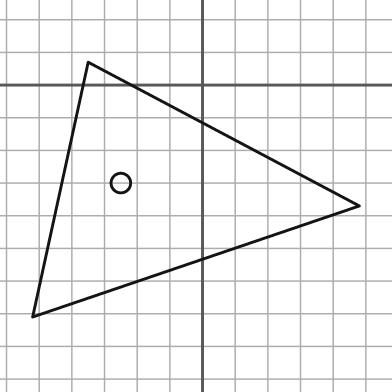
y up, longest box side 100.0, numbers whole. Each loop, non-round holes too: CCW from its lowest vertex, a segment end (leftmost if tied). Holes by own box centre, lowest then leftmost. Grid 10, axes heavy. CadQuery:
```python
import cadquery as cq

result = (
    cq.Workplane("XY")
    .moveTo(-52.0, -71.0)
    .lineTo(48.0, -37.0)
    .lineTo(-35.0, 7.0)
    .close()
    .moveTo(-25.0, -30.0)
    .circle(3.0)
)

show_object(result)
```